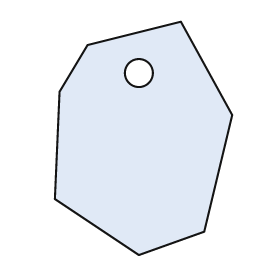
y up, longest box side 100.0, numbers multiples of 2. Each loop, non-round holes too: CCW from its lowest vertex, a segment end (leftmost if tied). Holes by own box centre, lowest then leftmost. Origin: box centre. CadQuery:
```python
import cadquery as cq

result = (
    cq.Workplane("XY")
    .moveTo(-2.0, -50.0)
    .lineTo(26.0, -40.0)
    .lineTo(38.0, 10.0)
    .lineTo(16.0, 50.0)
    .lineTo(-24.0, 40.0)
    .lineTo(-36.0, 20.0)
    .lineTo(-38.0, -26.0)
    .close()
    .moveTo(-2.0, 28.0)
    .circle(6.0)
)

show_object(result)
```